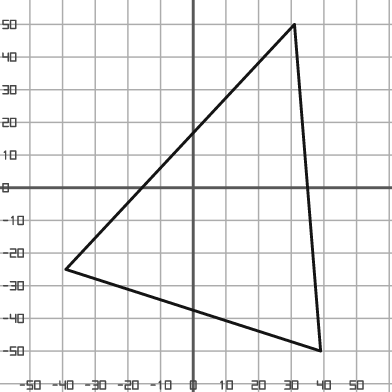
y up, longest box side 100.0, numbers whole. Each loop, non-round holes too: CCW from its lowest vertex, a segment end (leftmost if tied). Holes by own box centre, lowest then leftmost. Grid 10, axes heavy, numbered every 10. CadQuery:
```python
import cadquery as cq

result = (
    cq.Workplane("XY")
    .moveTo(39.0, -50.0)
    .lineTo(31.0, 50.0)
    .lineTo(-39.0, -25.0)
    .close()
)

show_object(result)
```